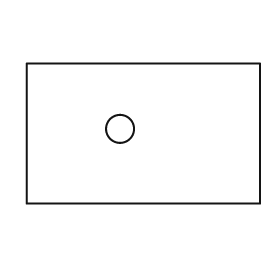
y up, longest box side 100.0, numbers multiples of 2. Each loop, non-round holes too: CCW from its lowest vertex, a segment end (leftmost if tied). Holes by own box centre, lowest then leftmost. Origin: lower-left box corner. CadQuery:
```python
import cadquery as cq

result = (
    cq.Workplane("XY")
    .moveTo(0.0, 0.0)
    .lineTo(100.0, 0.0)
    .lineTo(100.0, 60.0)
    .lineTo(0.0, 60.0)
    .close()
    .moveTo(40.0, 32.0)
    .circle(6.0)
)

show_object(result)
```